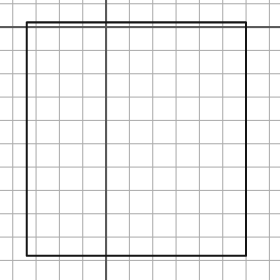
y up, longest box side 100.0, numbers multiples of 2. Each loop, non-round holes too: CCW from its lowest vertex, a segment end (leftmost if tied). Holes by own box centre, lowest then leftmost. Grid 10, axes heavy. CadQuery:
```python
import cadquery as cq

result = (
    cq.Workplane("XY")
    .moveTo(-34.0, -98.0)
    .lineTo(60.0, -98.0)
    .lineTo(60.0, 2.0)
    .lineTo(-34.0, 2.0)
    .close()
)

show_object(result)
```